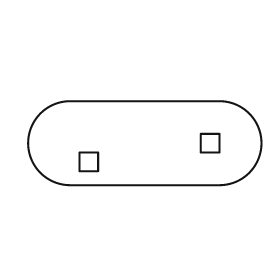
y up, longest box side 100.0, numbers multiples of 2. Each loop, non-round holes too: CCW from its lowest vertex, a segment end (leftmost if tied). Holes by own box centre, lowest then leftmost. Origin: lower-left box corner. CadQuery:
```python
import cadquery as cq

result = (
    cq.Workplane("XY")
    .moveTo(18.0, 0.0)
    .lineTo(82.0, 0.0)
    .threePointArc((100.0, 18.0), (82.0, 36.0))
    .lineTo(18.0, 36.0)
    .threePointArc((0.0, 18.0), (18.0, 0.0))
    .close()
    .moveTo(22.0, 6.0)
    .lineTo(30.0, 6.0)
    .lineTo(30.0, 14.0)
    .lineTo(22.0, 14.0)
    .close()
    .moveTo(74.0, 14.0)
    .lineTo(82.0, 14.0)
    .lineTo(82.0, 22.0)
    .lineTo(74.0, 22.0)
    .close()
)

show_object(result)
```